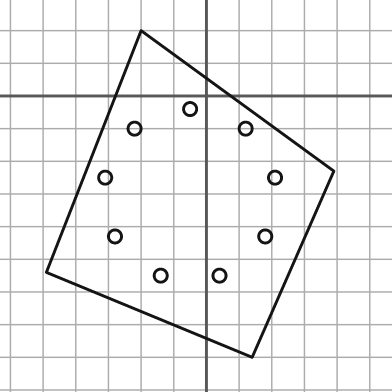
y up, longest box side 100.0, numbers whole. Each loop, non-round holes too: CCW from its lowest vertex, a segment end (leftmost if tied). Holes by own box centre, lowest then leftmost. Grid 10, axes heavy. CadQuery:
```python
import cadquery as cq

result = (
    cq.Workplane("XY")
    .moveTo(14.0, -80.0)
    .lineTo(39.0, -23.0)
    .lineTo(-20.0, 20.0)
    .lineTo(-49.0, -54.0)
    .close()
    .moveTo(-14.0, -55.0)
    .circle(2.0)
    .moveTo(4.0, -55.0)
    .circle(2.0)
    .moveTo(-28.0, -43.0)
    .circle(2.0)
    .moveTo(18.0, -43.0)
    .circle(2.0)
    .moveTo(-31.0, -25.0)
    .circle(2.0)
    .moveTo(21.0, -25.0)
    .circle(2.0)
    .moveTo(-22.0, -10.0)
    .circle(2.0)
    .moveTo(12.0, -10.0)
    .circle(2.0)
    .moveTo(-5.0, -4.0)
    .circle(2.0)
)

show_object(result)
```